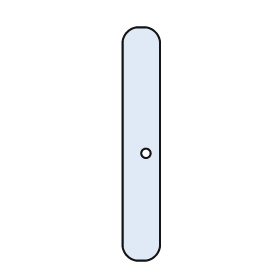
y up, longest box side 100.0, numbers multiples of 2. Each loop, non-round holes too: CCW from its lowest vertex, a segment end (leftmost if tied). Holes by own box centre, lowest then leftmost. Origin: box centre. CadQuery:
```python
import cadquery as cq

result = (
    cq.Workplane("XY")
    .moveTo(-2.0, -50.0)
    .lineTo(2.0, -50.0)
    .threePointArc((6.0, -48.0), (8.0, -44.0))
    .lineTo(8.0, 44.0)
    .threePointArc((6.0, 48.0), (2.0, 50.0))
    .lineTo(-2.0, 50.0)
    .threePointArc((-6.0, 48.0), (-8.0, 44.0))
    .lineTo(-8.0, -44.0)
    .threePointArc((-6.0, -48.0), (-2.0, -50.0))
    .close()
    .moveTo(2.0, -4.0)
    .circle(2.0)
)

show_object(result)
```